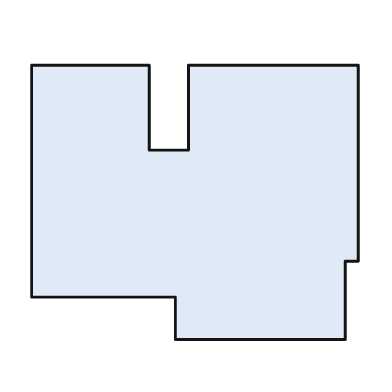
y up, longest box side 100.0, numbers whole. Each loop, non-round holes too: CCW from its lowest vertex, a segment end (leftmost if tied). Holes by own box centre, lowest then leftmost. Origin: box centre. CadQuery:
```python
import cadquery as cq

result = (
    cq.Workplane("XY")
    .moveTo(-6.0, -42.0)
    .lineTo(46.0, -42.0)
    .lineTo(46.0, -18.0)
    .lineTo(50.0, -18.0)
    .lineTo(50.0, 42.0)
    .lineTo(-2.0, 42.0)
    .lineTo(-2.0, 16.0)
    .lineTo(-14.0, 16.0)
    .lineTo(-14.0, 42.0)
    .lineTo(-50.0, 42.0)
    .lineTo(-50.0, -29.0)
    .lineTo(-6.0, -29.0)
    .close()
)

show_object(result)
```